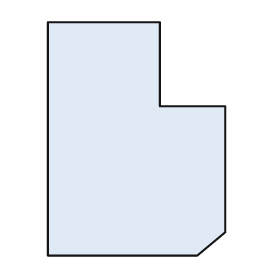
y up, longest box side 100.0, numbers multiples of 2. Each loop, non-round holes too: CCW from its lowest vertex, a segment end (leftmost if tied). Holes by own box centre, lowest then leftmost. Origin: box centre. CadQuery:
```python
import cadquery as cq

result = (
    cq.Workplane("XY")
    .moveTo(-38.0, -50.0)
    .lineTo(26.0, -50.0)
    .lineTo(38.0, -40.0)
    .lineTo(38.0, 14.0)
    .lineTo(10.0, 14.0)
    .lineTo(10.0, 50.0)
    .lineTo(-38.0, 50.0)
    .close()
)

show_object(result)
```